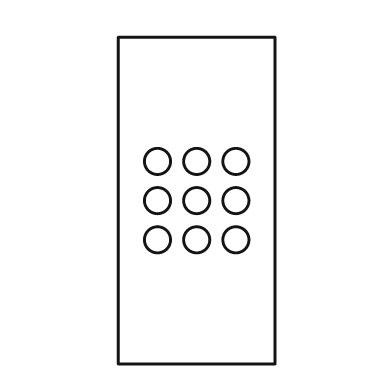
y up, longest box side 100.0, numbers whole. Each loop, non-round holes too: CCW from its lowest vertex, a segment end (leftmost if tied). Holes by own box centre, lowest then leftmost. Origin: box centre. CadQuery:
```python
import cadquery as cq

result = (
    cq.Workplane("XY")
    .moveTo(-24.0, -50.0)
    .lineTo(24.0, -50.0)
    .lineTo(24.0, 50.0)
    .lineTo(-24.0, 50.0)
    .close()
    .moveTo(-12.0, -12.0)
    .circle(4.0)
    .moveTo(0.0, -12.0)
    .circle(4.0)
    .moveTo(12.0, -12.0)
    .circle(4.0)
    .moveTo(-12.0, 0.0)
    .circle(4.0)
    .moveTo(0.0, 0.0)
    .circle(4.0)
    .moveTo(12.0, 0.0)
    .circle(4.0)
    .moveTo(-12.0, 12.0)
    .circle(4.0)
    .moveTo(0.0, 12.0)
    .circle(4.0)
    .moveTo(12.0, 12.0)
    .circle(4.0)
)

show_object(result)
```